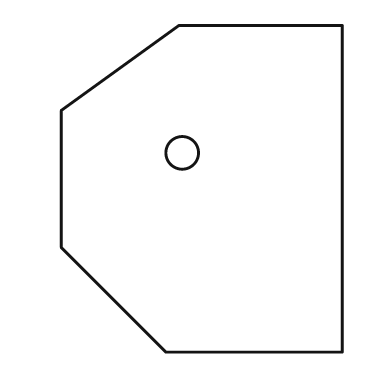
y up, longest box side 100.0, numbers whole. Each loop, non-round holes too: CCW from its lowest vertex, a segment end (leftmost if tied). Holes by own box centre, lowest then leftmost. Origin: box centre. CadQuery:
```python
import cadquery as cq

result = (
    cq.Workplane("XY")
    .moveTo(-11.0, -50.0)
    .lineTo(43.0, -50.0)
    .lineTo(43.0, 50.0)
    .lineTo(-7.0, 50.0)
    .lineTo(-43.0, 24.0)
    .lineTo(-43.0, -18.0)
    .close()
    .moveTo(-6.0, 11.0)
    .circle(5.0)
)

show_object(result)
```